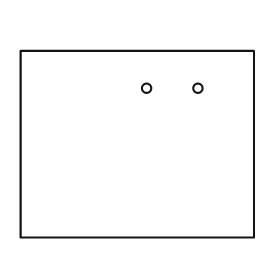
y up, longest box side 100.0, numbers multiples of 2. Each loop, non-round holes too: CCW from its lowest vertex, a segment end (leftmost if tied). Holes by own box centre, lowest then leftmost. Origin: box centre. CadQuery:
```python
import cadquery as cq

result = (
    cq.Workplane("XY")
    .moveTo(-50.0, -40.0)
    .lineTo(50.0, -40.0)
    .lineTo(50.0, 40.0)
    .lineTo(-50.0, 40.0)
    .close()
    .moveTo(4.0, 24.0)
    .circle(2.0)
    .moveTo(26.0, 24.0)
    .circle(2.0)
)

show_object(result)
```